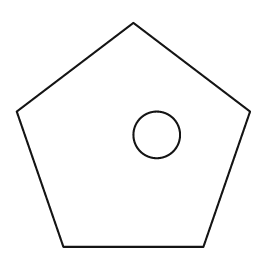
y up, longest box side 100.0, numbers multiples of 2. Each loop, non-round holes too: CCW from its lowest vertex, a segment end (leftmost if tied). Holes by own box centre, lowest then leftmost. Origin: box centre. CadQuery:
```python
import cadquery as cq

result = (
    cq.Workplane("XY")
    .moveTo(-30.0, -48.0)
    .lineTo(30.0, -48.0)
    .lineTo(50.0, 10.0)
    .lineTo(0.0, 48.0)
    .lineTo(-50.0, 10.0)
    .close()
    .moveTo(10.0, 0.0)
    .circle(10.0)
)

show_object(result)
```